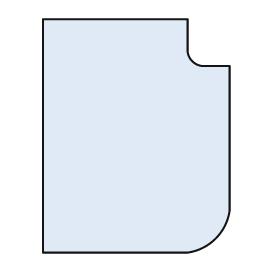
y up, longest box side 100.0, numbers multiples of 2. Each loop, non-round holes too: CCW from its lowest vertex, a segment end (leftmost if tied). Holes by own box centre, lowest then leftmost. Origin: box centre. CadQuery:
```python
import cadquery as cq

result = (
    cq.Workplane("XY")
    .moveTo(-40.0, -50.0)
    .lineTo(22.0, -50.0)
    .threePointArc((34.0, -44.0), (40.0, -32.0))
    .lineTo(40.0, 30.0)
    .lineTo(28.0, 30.0)
    .threePointArc((24.0, 32.0), (22.0, 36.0))
    .lineTo(22.0, 50.0)
    .lineTo(-40.0, 50.0)
    .close()
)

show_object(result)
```